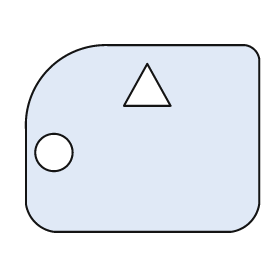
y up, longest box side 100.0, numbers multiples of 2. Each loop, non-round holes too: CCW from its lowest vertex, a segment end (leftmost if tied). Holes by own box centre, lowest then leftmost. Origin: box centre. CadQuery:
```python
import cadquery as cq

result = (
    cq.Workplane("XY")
    .moveTo(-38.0, -40.0)
    .lineTo(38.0, -40.0)
    .threePointArc((46.0, -36.0), (50.0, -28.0))
    .lineTo(50.0, 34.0)
    .threePointArc((48.0, 38.0), (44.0, 40.0))
    .lineTo(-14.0, 40.0)
    .threePointArc((-40.0, 30.0), (-50.0, 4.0))
    .lineTo(-50.0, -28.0)
    .threePointArc((-46.0, -36.0), (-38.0, -40.0))
    .close()
    .moveTo(-38.0, -6.0)
    .circle(8.0)
    .moveTo(-8.0, 14.0)
    .lineTo(12.0, 14.0)
    .lineTo(2.0, 32.0)
    .close()
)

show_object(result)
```